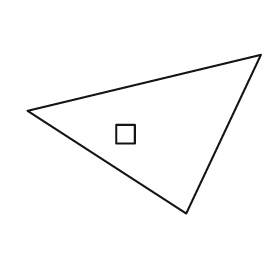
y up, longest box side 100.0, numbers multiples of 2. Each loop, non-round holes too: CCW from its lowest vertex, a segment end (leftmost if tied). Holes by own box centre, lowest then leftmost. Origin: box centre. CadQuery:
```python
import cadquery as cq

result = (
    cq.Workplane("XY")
    .moveTo(18.0, -34.0)
    .lineTo(50.0, 34.0)
    .lineTo(-50.0, 10.0)
    .close()
    .moveTo(-12.0, -4.0)
    .lineTo(-4.0, -4.0)
    .lineTo(-4.0, 4.0)
    .lineTo(-12.0, 4.0)
    .close()
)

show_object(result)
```